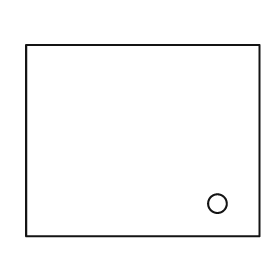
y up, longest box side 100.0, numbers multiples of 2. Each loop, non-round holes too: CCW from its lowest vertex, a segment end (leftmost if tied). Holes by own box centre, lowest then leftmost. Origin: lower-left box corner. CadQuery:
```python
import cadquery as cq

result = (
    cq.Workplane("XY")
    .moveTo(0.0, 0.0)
    .lineTo(100.0, 0.0)
    .lineTo(100.0, 82.0)
    .lineTo(0.0, 82.0)
    .close()
    .moveTo(82.0, 14.0)
    .circle(4.0)
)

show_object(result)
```